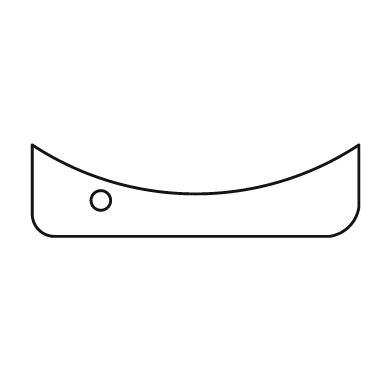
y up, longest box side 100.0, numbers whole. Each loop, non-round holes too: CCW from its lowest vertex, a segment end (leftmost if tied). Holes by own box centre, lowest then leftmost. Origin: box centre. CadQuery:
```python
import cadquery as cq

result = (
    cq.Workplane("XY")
    .moveTo(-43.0, -14.0)
    .lineTo(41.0, -14.0)
    .threePointArc((47.0, -11.0), (50.0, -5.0))
    .lineTo(50.0, 14.0)
    .threePointArc((0.0, -1.0), (-50.0, 14.0))
    .lineTo(-50.0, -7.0)
    .threePointArc((-48.0, -12.0), (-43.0, -14.0))
    .close()
    .moveTo(-29.0, -3.0)
    .circle(3.0)
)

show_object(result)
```